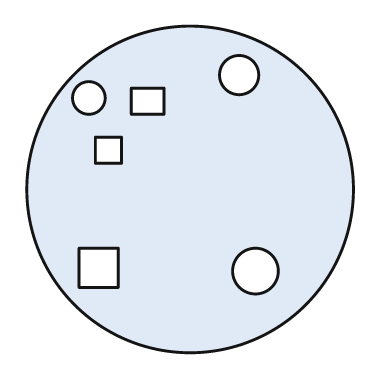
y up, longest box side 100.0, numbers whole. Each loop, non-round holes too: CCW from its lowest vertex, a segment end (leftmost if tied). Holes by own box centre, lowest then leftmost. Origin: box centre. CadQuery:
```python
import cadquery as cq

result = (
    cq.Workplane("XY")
    .moveTo(0.0, 0.0)
    .circle(50.0)
    .moveTo(20.0, -25.0)
    .circle(7.0)
    .moveTo(-34.0, -30.0)
    .lineTo(-22.0, -30.0)
    .lineTo(-22.0, -18.0)
    .lineTo(-34.0, -18.0)
    .close()
    .moveTo(-29.0, 8.0)
    .lineTo(-21.0, 8.0)
    .lineTo(-21.0, 16.0)
    .lineTo(-29.0, 16.0)
    .close()
    .moveTo(-18.0, 23.0)
    .lineTo(-8.0, 23.0)
    .lineTo(-8.0, 31.0)
    .lineTo(-18.0, 31.0)
    .close()
    .moveTo(-31.0, 28.0)
    .circle(5.0)
    .moveTo(15.0, 35.0)
    .circle(6.0)
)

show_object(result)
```